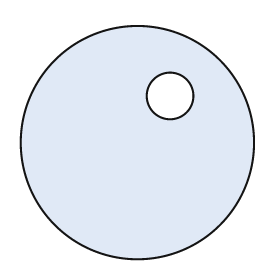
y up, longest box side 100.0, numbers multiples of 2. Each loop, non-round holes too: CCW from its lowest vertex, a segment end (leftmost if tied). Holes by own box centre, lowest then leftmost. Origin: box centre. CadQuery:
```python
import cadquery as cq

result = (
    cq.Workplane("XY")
    .moveTo(0.0, 0.0)
    .circle(50.0)
    .moveTo(14.0, 20.0)
    .circle(10.0)
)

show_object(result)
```